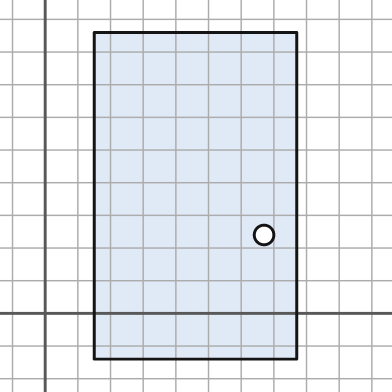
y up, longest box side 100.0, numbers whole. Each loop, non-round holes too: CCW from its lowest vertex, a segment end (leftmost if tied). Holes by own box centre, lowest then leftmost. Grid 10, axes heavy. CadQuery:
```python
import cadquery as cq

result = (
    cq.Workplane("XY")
    .moveTo(15.0, -14.0)
    .lineTo(77.0, -14.0)
    .lineTo(77.0, 86.0)
    .lineTo(15.0, 86.0)
    .close()
    .moveTo(67.0, 24.0)
    .circle(3.0)
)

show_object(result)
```